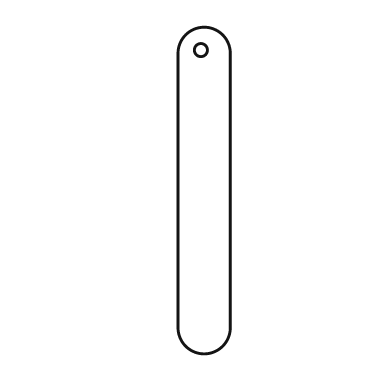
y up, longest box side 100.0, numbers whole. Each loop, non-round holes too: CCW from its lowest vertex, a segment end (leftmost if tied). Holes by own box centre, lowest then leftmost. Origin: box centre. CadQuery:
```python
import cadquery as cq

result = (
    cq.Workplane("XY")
    .moveTo(-8.0, -42.0)
    .threePointArc((0.0, -50.0), (8.0, -42.0))
    .lineTo(8.0, 42.0)
    .threePointArc((0.0, 50.0), (-8.0, 42.0))
    .close()
    .moveTo(-1.0, 43.0)
    .circle(2.0)
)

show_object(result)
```